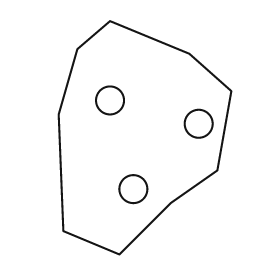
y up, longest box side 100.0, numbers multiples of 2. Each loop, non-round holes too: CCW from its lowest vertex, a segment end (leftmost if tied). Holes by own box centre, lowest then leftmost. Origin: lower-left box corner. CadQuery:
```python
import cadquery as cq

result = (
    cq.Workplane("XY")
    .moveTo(26.0, 0.0)
    .lineTo(48.0, 22.0)
    .lineTo(68.0, 36.0)
    .lineTo(74.0, 70.0)
    .lineTo(56.0, 86.0)
    .lineTo(22.0, 100.0)
    .lineTo(8.0, 88.0)
    .lineTo(0.0, 60.0)
    .lineTo(2.0, 10.0)
    .close()
    .moveTo(32.0, 28.0)
    .circle(6.0)
    .moveTo(60.0, 56.0)
    .circle(6.0)
    .moveTo(22.0, 66.0)
    .circle(6.0)
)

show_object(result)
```